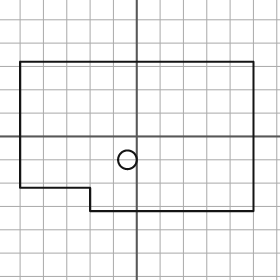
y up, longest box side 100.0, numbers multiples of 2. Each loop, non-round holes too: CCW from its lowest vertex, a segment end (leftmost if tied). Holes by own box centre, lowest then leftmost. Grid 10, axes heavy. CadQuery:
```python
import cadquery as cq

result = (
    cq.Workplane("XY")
    .moveTo(-20.0, -32.0)
    .lineTo(50.0, -32.0)
    .lineTo(50.0, 32.0)
    .lineTo(-50.0, 32.0)
    .lineTo(-50.0, -22.0)
    .lineTo(-20.0, -22.0)
    .close()
    .moveTo(-4.0, -10.0)
    .circle(4.0)
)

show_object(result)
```